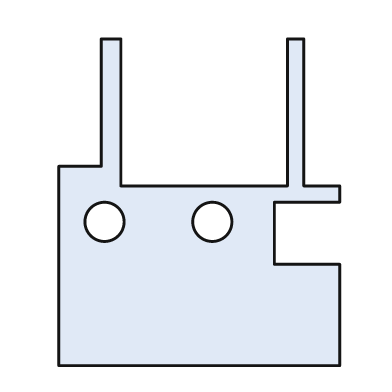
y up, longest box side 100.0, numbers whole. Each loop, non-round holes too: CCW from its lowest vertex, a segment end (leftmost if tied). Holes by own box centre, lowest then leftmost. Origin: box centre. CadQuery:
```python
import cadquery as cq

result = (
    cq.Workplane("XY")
    .moveTo(-43.0, -50.0)
    .lineTo(43.0, -50.0)
    .lineTo(43.0, -19.0)
    .lineTo(23.0, -19.0)
    .lineTo(23.0, 0.0)
    .lineTo(43.0, 0.0)
    .lineTo(43.0, 5.0)
    .lineTo(32.0, 5.0)
    .lineTo(32.0, 50.0)
    .lineTo(27.0, 50.0)
    .lineTo(27.0, 5.0)
    .lineTo(-24.0, 5.0)
    .lineTo(-24.0, 50.0)
    .lineTo(-30.0, 50.0)
    .lineTo(-30.0, 11.0)
    .lineTo(-43.0, 11.0)
    .close()
    .moveTo(-29.0, -6.0)
    .circle(6.0)
    .moveTo(4.0, -6.0)
    .circle(6.0)
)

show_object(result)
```